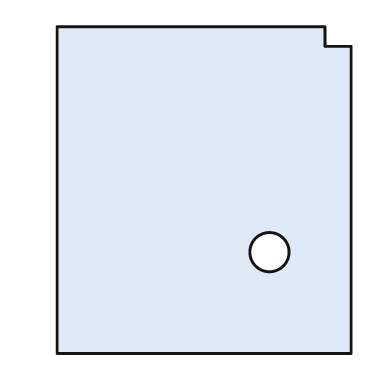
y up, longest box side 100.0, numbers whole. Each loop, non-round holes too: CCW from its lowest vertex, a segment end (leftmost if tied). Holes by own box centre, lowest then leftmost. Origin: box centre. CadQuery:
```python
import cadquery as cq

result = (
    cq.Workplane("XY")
    .moveTo(-45.0, -50.0)
    .lineTo(45.0, -50.0)
    .lineTo(45.0, 44.0)
    .lineTo(37.0, 44.0)
    .lineTo(37.0, 50.0)
    .lineTo(-45.0, 50.0)
    .close()
    .moveTo(20.0, -19.0)
    .circle(6.0)
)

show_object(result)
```